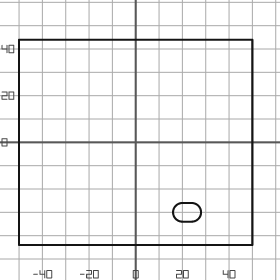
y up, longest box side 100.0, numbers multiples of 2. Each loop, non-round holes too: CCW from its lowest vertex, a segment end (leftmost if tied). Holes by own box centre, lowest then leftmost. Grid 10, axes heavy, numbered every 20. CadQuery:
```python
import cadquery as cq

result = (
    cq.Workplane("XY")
    .moveTo(-50.0, -44.0)
    .lineTo(50.0, -44.0)
    .lineTo(50.0, 44.0)
    .lineTo(-50.0, 44.0)
    .close()
    .moveTo(20.0, -34.0)
    .lineTo(24.0, -34.0)
    .threePointArc((28.0, -30.0), (24.0, -26.0))
    .lineTo(20.0, -26.0)
    .threePointArc((16.0, -30.0), (20.0, -34.0))
    .close()
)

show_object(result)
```